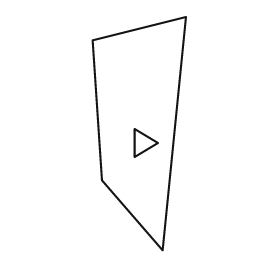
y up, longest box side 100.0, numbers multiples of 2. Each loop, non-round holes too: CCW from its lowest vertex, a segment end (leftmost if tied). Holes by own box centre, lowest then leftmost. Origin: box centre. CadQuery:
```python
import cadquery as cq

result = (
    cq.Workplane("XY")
    .moveTo(10.0, -50.0)
    .lineTo(20.0, 50.0)
    .lineTo(-20.0, 40.0)
    .lineTo(-16.0, -20.0)
    .close()
    .moveTo(-2.0, -10.0)
    .lineTo(8.0, -4.0)
    .lineTo(-2.0, 2.0)
    .close()
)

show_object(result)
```